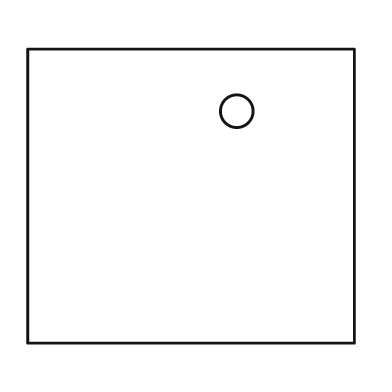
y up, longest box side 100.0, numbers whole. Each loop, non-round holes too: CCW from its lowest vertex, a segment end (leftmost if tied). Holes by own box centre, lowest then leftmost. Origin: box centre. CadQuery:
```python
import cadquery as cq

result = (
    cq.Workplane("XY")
    .moveTo(-50.0, -45.0)
    .lineTo(50.0, -45.0)
    .lineTo(50.0, 45.0)
    .lineTo(-50.0, 45.0)
    .close()
    .moveTo(14.0, 26.0)
    .circle(5.0)
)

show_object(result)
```